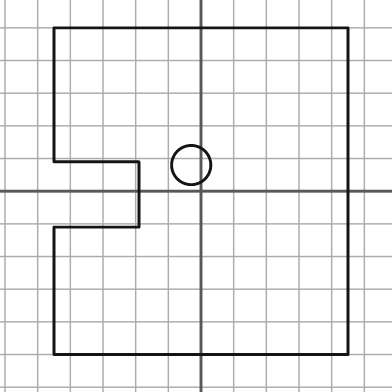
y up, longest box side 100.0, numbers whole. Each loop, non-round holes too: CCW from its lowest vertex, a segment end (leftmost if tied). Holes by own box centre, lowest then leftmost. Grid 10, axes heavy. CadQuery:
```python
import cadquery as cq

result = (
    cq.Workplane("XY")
    .moveTo(-45.0, -50.0)
    .lineTo(45.0, -50.0)
    .lineTo(45.0, 50.0)
    .lineTo(-45.0, 50.0)
    .lineTo(-45.0, 9.0)
    .lineTo(-19.0, 9.0)
    .lineTo(-19.0, -11.0)
    .lineTo(-45.0, -11.0)
    .close()
    .moveTo(-3.0, 8.0)
    .circle(6.0)
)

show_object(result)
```